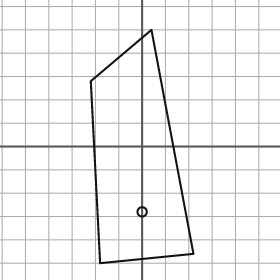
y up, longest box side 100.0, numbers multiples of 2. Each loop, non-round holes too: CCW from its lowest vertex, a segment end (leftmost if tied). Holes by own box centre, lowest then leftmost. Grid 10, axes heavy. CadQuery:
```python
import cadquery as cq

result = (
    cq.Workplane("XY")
    .moveTo(-18.0, -50.0)
    .lineTo(22.0, -46.0)
    .lineTo(4.0, 50.0)
    .lineTo(-22.0, 28.0)
    .close()
    .moveTo(0.0, -28.0)
    .circle(2.0)
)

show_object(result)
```